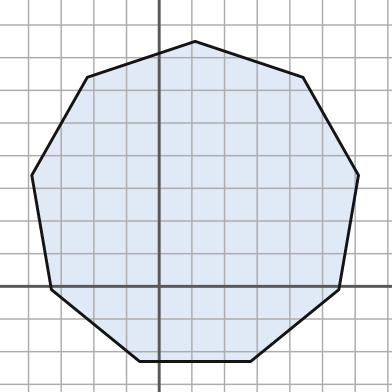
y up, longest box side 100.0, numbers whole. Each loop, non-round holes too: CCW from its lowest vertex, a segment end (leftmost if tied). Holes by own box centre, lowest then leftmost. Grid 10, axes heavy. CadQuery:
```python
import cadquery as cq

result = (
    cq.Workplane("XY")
    .moveTo(-6.0, -23.0)
    .lineTo(28.0, -23.0)
    .lineTo(55.0, -1.0)
    .lineTo(61.0, 34.0)
    .lineTo(44.0, 64.0)
    .lineTo(11.0, 75.0)
    .lineTo(-22.0, 64.0)
    .lineTo(-39.0, 34.0)
    .lineTo(-33.0, -1.0)
    .close()
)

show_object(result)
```